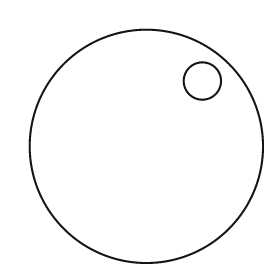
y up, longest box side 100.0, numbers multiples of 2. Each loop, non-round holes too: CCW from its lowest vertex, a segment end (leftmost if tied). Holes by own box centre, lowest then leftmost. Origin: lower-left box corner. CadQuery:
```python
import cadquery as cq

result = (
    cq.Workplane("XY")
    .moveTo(50.0, 50.0)
    .circle(50.0)
    .moveTo(74.0, 78.0)
    .circle(8.0)
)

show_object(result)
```